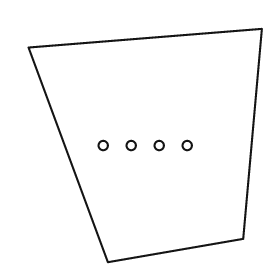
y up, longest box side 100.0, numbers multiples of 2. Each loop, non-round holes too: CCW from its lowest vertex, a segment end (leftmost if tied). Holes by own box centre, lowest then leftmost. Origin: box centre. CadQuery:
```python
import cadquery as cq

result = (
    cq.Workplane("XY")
    .moveTo(-16.0, -50.0)
    .lineTo(42.0, -40.0)
    .lineTo(50.0, 50.0)
    .lineTo(-50.0, 42.0)
    .close()
    .moveTo(-18.0, 0.0)
    .circle(2.0)
    .moveTo(-6.0, 0.0)
    .circle(2.0)
    .moveTo(6.0, 0.0)
    .circle(2.0)
    .moveTo(18.0, 0.0)
    .circle(2.0)
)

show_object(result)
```